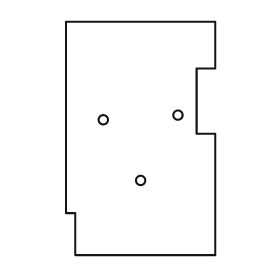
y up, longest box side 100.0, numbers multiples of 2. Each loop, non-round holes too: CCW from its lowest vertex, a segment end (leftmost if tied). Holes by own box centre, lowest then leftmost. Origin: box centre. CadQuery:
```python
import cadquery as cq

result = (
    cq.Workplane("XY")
    .moveTo(-28.0, -50.0)
    .lineTo(32.0, -50.0)
    .lineTo(32.0, 2.0)
    .lineTo(24.0, 2.0)
    .lineTo(24.0, 30.0)
    .lineTo(32.0, 30.0)
    .lineTo(32.0, 50.0)
    .lineTo(-32.0, 50.0)
    .lineTo(-32.0, -32.0)
    .lineTo(-28.0, -32.0)
    .close()
    .moveTo(0.0, -18.0)
    .circle(2.0)
    .moveTo(-16.0, 8.0)
    .circle(2.0)
    .moveTo(16.0, 10.0)
    .circle(2.0)
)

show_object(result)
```